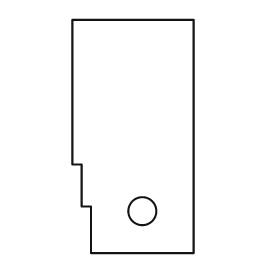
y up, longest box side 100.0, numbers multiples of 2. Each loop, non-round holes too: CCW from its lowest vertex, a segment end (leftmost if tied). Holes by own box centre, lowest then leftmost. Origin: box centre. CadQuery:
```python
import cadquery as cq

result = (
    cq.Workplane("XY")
    .moveTo(-18.0, -50.0)
    .lineTo(26.0, -50.0)
    .lineTo(26.0, 50.0)
    .lineTo(-26.0, 50.0)
    .lineTo(-26.0, -12.0)
    .lineTo(-22.0, -12.0)
    .lineTo(-22.0, -30.0)
    .lineTo(-18.0, -30.0)
    .close()
    .moveTo(4.0, -32.0)
    .circle(6.0)
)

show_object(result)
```